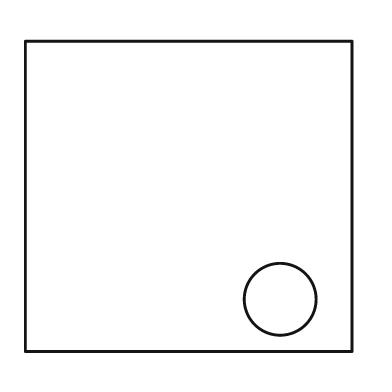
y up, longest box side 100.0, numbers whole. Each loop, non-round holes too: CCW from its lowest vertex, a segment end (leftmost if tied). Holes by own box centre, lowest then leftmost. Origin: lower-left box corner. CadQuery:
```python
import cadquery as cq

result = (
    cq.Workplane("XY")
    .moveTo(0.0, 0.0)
    .lineTo(100.0, 0.0)
    .lineTo(100.0, 95.0)
    .lineTo(0.0, 95.0)
    .close()
    .moveTo(78.0, 16.0)
    .circle(11.0)
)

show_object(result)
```